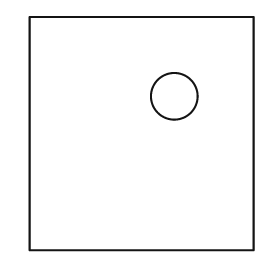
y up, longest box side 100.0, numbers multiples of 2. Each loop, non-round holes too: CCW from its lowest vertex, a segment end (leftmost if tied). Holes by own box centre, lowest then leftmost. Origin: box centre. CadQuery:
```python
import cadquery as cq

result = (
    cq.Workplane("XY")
    .moveTo(-48.0, -50.0)
    .lineTo(48.0, -50.0)
    .lineTo(48.0, 50.0)
    .lineTo(-48.0, 50.0)
    .close()
    .moveTo(14.0, 16.0)
    .circle(10.0)
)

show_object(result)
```